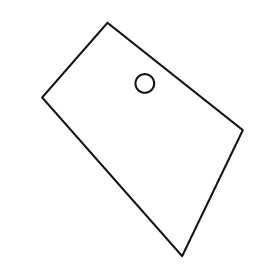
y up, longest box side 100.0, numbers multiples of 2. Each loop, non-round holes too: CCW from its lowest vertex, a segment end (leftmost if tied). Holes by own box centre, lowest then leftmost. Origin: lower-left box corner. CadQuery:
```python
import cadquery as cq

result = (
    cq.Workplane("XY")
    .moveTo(60.0, 0.0)
    .lineTo(86.0, 54.0)
    .lineTo(28.0, 100.0)
    .lineTo(0.0, 68.0)
    .close()
    .moveTo(44.0, 74.0)
    .circle(4.0)
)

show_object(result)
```